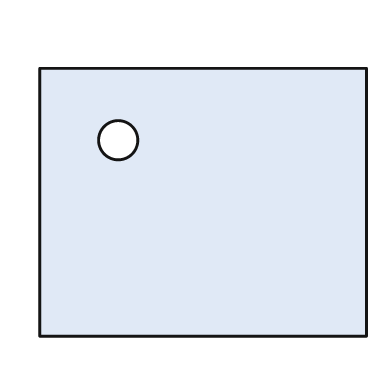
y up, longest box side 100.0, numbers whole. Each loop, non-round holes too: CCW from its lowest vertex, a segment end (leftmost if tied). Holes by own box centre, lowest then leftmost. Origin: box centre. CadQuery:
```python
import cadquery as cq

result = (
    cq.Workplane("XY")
    .moveTo(-50.0, -41.0)
    .lineTo(50.0, -41.0)
    .lineTo(50.0, 41.0)
    .lineTo(-50.0, 41.0)
    .close()
    .moveTo(-26.0, 19.0)
    .circle(6.0)
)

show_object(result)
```